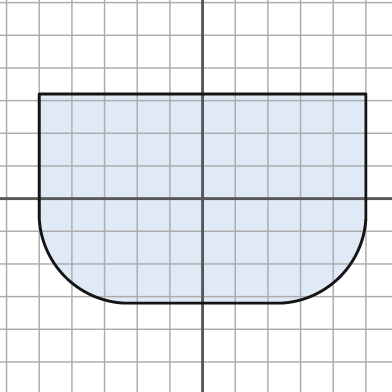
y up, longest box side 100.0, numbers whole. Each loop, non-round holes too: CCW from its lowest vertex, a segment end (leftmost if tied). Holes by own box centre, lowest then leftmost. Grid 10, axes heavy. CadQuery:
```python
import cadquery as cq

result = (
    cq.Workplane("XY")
    .moveTo(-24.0, -32.0)
    .lineTo(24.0, -32.0)
    .threePointArc((42.0, -24.0), (50.0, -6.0))
    .lineTo(50.0, 32.0)
    .lineTo(-50.0, 32.0)
    .lineTo(-50.0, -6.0)
    .threePointArc((-42.0, -24.0), (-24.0, -32.0))
    .close()
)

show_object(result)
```